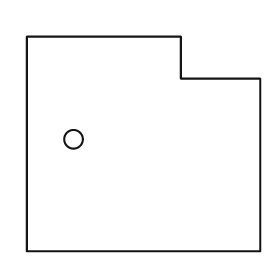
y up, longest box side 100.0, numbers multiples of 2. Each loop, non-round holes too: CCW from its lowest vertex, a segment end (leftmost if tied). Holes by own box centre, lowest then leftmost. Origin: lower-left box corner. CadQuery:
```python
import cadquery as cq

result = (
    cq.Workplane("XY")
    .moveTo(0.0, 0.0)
    .lineTo(100.0, 0.0)
    .lineTo(100.0, 74.0)
    .lineTo(66.0, 74.0)
    .lineTo(66.0, 92.0)
    .lineTo(0.0, 92.0)
    .close()
    .moveTo(20.0, 48.0)
    .circle(4.0)
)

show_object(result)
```